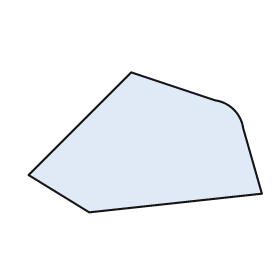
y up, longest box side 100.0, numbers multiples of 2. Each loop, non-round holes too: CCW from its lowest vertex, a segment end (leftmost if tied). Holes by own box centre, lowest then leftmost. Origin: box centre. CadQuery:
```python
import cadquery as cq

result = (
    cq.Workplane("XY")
    .moveTo(-24.0, -30.0)
    .lineTo(50.0, -22.0)
    .lineTo(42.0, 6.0)
    .threePointArc((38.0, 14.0), (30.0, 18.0))
    .lineTo(-6.0, 30.0)
    .lineTo(-50.0, -14.0)
    .close()
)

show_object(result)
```